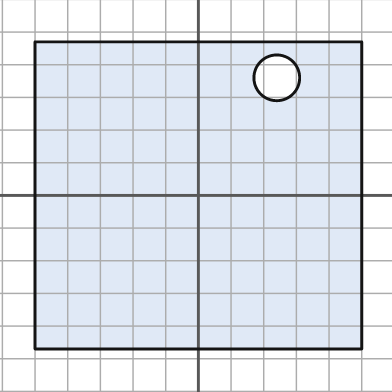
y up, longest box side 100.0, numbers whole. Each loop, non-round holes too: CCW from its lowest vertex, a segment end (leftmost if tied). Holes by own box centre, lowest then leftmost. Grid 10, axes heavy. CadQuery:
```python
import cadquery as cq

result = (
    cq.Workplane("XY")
    .moveTo(-50.0, -47.0)
    .lineTo(50.0, -47.0)
    .lineTo(50.0, 47.0)
    .lineTo(-50.0, 47.0)
    .close()
    .moveTo(24.0, 36.0)
    .circle(7.0)
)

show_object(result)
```